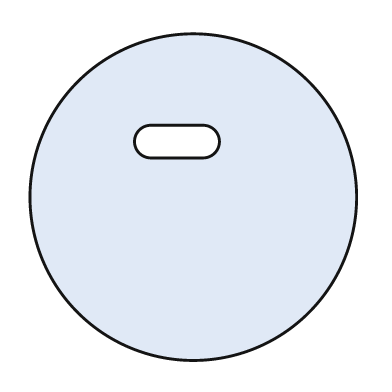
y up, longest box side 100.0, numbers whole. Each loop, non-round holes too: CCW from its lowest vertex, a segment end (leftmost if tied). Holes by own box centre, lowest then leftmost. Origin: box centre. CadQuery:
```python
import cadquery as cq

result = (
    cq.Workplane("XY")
    .moveTo(0.0, 0.0)
    .circle(50.0)
    .moveTo(-13.0, 12.0)
    .lineTo(3.0, 12.0)
    .threePointArc((8.0, 17.0), (3.0, 22.0))
    .lineTo(-13.0, 22.0)
    .threePointArc((-18.0, 17.0), (-13.0, 12.0))
    .close()
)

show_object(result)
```